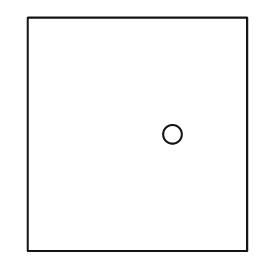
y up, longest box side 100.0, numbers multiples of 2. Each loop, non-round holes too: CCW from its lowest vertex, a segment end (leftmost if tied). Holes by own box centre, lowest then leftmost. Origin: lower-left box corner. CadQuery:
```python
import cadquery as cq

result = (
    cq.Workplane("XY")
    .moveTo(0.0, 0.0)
    .lineTo(94.0, 0.0)
    .lineTo(94.0, 100.0)
    .lineTo(0.0, 100.0)
    .close()
    .moveTo(62.0, 50.0)
    .circle(4.0)
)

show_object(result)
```